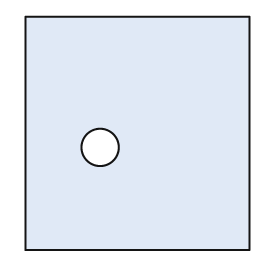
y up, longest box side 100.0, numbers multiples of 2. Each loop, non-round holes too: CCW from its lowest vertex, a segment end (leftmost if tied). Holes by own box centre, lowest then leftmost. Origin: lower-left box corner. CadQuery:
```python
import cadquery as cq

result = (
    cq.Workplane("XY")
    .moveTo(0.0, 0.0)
    .lineTo(96.0, 0.0)
    .lineTo(96.0, 100.0)
    .lineTo(0.0, 100.0)
    .close()
    .moveTo(32.0, 44.0)
    .circle(8.0)
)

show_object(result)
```